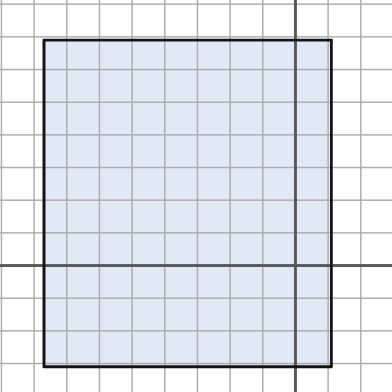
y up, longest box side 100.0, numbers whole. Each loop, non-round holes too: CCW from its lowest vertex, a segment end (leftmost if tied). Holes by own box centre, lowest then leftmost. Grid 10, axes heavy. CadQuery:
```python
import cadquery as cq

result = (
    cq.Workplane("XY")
    .moveTo(-77.0, -31.0)
    .lineTo(11.0, -31.0)
    .lineTo(11.0, 69.0)
    .lineTo(-77.0, 69.0)
    .close()
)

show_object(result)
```